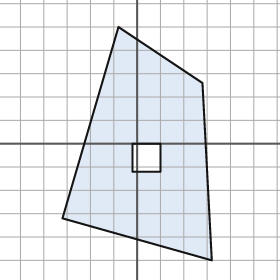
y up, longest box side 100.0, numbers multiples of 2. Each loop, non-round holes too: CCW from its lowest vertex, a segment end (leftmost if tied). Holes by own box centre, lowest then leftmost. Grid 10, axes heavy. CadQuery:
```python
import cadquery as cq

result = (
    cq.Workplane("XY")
    .moveTo(32.0, -50.0)
    .lineTo(28.0, 26.0)
    .lineTo(-8.0, 50.0)
    .lineTo(-32.0, -32.0)
    .close()
    .moveTo(-2.0, -12.0)
    .lineTo(10.0, -12.0)
    .lineTo(10.0, 0.0)
    .lineTo(-2.0, 0.0)
    .close()
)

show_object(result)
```